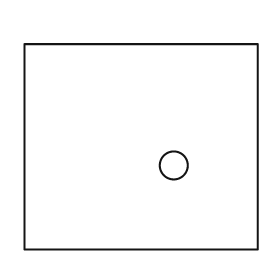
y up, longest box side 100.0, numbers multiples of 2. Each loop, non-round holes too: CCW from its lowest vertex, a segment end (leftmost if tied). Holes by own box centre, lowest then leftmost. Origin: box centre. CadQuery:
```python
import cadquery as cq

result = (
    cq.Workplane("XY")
    .moveTo(-50.0, -44.0)
    .lineTo(50.0, -44.0)
    .lineTo(50.0, 44.0)
    .lineTo(-50.0, 44.0)
    .close()
    .moveTo(14.0, -8.0)
    .circle(6.0)
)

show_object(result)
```